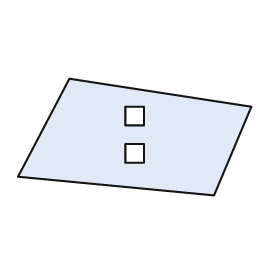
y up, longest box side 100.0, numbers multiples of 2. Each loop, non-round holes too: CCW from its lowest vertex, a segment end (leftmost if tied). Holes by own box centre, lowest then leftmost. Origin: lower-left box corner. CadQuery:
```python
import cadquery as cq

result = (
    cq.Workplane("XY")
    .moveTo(84.0, 0.0)
    .lineTo(100.0, 38.0)
    .lineTo(22.0, 50.0)
    .lineTo(0.0, 8.0)
    .close()
    .moveTo(46.0, 14.0)
    .lineTo(54.0, 14.0)
    .lineTo(54.0, 22.0)
    .lineTo(46.0, 22.0)
    .close()
    .moveTo(46.0, 30.0)
    .lineTo(54.0, 30.0)
    .lineTo(54.0, 38.0)
    .lineTo(46.0, 38.0)
    .close()
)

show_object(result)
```